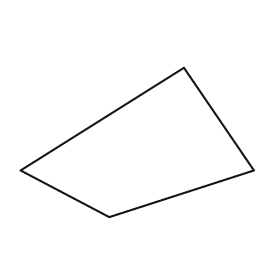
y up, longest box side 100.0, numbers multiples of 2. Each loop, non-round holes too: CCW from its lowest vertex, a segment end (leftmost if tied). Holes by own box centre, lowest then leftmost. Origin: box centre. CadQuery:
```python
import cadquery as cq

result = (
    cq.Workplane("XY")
    .moveTo(-12.0, -32.0)
    .lineTo(50.0, -12.0)
    .lineTo(20.0, 32.0)
    .lineTo(-50.0, -12.0)
    .close()
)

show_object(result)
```